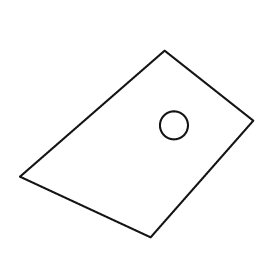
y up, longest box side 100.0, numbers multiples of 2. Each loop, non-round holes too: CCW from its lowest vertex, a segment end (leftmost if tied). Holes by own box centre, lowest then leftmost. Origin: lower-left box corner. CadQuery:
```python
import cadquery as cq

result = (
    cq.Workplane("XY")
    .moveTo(56.0, 0.0)
    .lineTo(100.0, 50.0)
    .lineTo(62.0, 80.0)
    .lineTo(0.0, 26.0)
    .close()
    .moveTo(66.0, 48.0)
    .circle(6.0)
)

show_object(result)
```